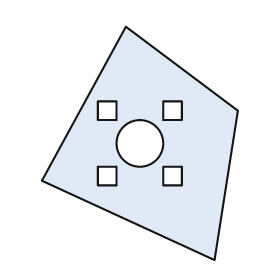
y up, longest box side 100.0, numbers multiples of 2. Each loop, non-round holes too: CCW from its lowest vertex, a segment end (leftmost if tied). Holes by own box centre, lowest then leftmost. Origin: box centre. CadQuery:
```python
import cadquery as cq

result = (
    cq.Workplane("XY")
    .moveTo(32.0, -50.0)
    .lineTo(42.0, 14.0)
    .lineTo(-6.0, 50.0)
    .lineTo(-42.0, -16.0)
    .close()
    .moveTo(-18.0, -18.0)
    .lineTo(-10.0, -18.0)
    .lineTo(-10.0, -10.0)
    .lineTo(-18.0, -10.0)
    .close()
    .moveTo(10.0, -18.0)
    .lineTo(18.0, -18.0)
    .lineTo(18.0, -10.0)
    .lineTo(10.0, -10.0)
    .close()
    .moveTo(0.0, 0.0)
    .circle(10.0)
    .moveTo(-18.0, 10.0)
    .lineTo(-10.0, 10.0)
    .lineTo(-10.0, 18.0)
    .lineTo(-18.0, 18.0)
    .close()
    .moveTo(10.0, 10.0)
    .lineTo(18.0, 10.0)
    .lineTo(18.0, 18.0)
    .lineTo(10.0, 18.0)
    .close()
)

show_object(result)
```